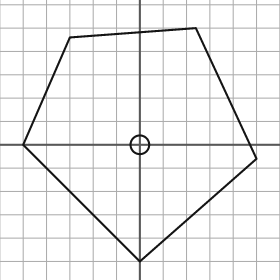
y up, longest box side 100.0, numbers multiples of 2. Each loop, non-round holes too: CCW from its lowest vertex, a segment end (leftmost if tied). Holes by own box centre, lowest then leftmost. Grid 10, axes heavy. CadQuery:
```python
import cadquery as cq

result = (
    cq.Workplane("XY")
    .moveTo(0.0, -50.0)
    .lineTo(50.0, -6.0)
    .lineTo(24.0, 50.0)
    .lineTo(-30.0, 46.0)
    .lineTo(-50.0, 0.0)
    .close()
    .moveTo(0.0, 0.0)
    .circle(4.0)
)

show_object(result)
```